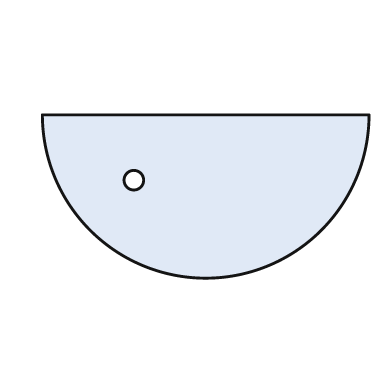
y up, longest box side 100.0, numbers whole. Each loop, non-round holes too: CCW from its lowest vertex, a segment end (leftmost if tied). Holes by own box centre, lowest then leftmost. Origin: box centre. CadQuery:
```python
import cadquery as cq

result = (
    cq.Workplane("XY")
    .moveTo(-50.0, 25.0)
    .threePointArc((0.0, -25.0), (50.0, 25.0))
    .close()
    .moveTo(-22.0, 5.0)
    .circle(3.0)
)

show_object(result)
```